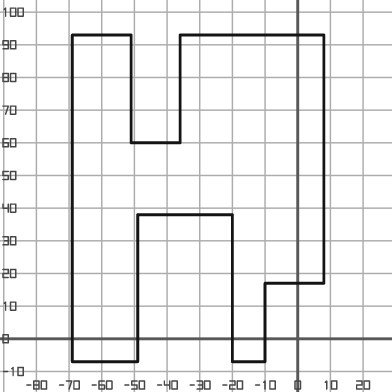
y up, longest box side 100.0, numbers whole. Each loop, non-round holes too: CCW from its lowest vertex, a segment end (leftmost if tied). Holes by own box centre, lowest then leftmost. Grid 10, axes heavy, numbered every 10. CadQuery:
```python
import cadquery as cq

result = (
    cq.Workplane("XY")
    .moveTo(-69.0, -7.0)
    .lineTo(-49.0, -7.0)
    .lineTo(-49.0, 38.0)
    .lineTo(-20.0, 38.0)
    .lineTo(-20.0, -7.0)
    .lineTo(-10.0, -7.0)
    .lineTo(-10.0, 17.0)
    .lineTo(8.0, 17.0)
    .lineTo(8.0, 93.0)
    .lineTo(-36.0, 93.0)
    .lineTo(-36.0, 60.0)
    .lineTo(-51.0, 60.0)
    .lineTo(-51.0, 93.0)
    .lineTo(-69.0, 93.0)
    .close()
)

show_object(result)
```